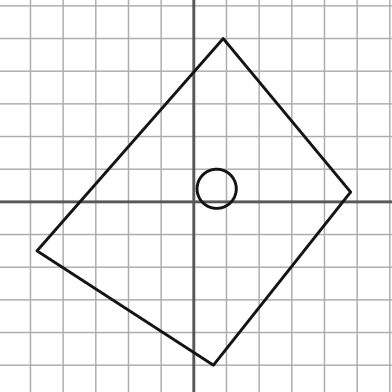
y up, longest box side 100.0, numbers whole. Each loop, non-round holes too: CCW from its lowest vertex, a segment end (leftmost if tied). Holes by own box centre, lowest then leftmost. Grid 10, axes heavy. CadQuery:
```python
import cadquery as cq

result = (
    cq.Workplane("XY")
    .moveTo(6.0, -50.0)
    .lineTo(48.0, 3.0)
    .lineTo(9.0, 50.0)
    .lineTo(-48.0, -15.0)
    .close()
    .moveTo(7.0, 4.0)
    .circle(6.0)
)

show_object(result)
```